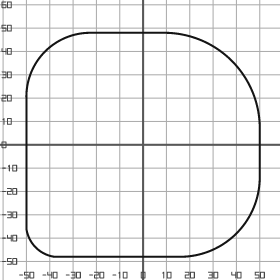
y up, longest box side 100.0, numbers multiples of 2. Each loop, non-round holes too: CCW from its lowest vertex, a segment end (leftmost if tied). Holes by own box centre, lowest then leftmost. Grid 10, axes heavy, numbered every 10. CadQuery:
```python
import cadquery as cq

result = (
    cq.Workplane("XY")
    .moveTo(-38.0, -48.0)
    .lineTo(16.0, -48.0)
    .threePointArc((40.0, -38.0), (50.0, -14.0))
    .lineTo(50.0, 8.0)
    .threePointArc((38.0, 36.0), (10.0, 48.0))
    .lineTo(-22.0, 48.0)
    .threePointArc((-42.0, 40.0), (-50.0, 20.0))
    .lineTo(-50.0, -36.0)
    .threePointArc((-46.0, -44.0), (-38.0, -48.0))
    .close()
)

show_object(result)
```